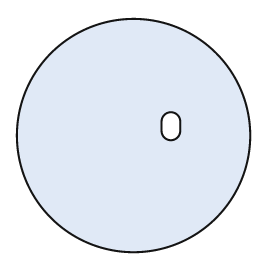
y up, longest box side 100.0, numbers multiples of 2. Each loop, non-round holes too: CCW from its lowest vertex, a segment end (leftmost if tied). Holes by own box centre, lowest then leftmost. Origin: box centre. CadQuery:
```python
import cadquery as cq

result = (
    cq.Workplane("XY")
    .moveTo(0.0, 0.0)
    .circle(50.0)
    .moveTo(12.0, 2.0)
    .threePointArc((16.0, -2.0), (20.0, 2.0))
    .lineTo(20.0, 6.0)
    .threePointArc((16.0, 10.0), (12.0, 6.0))
    .close()
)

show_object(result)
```